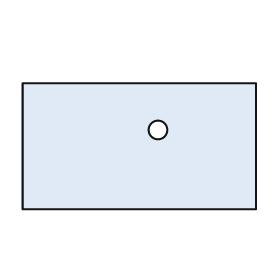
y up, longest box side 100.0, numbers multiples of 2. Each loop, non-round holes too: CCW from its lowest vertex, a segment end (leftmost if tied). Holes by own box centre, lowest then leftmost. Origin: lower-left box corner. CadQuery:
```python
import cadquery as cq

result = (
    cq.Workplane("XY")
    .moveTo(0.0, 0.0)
    .lineTo(100.0, 0.0)
    .lineTo(100.0, 54.0)
    .lineTo(0.0, 54.0)
    .close()
    .moveTo(58.0, 34.0)
    .circle(4.0)
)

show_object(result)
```